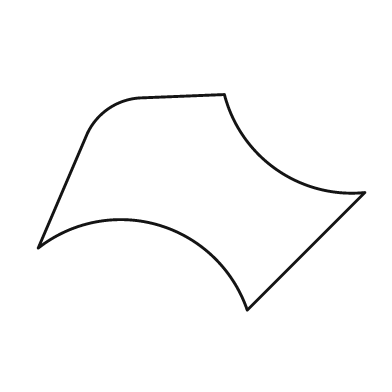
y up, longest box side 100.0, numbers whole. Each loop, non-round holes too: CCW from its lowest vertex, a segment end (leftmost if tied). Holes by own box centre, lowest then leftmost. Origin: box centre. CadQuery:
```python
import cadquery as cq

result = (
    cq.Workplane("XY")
    .moveTo(14.0, -33.0)
    .lineTo(50.0, 3.0)
    .threePointArc((23.0, 10.0), (7.0, 33.0))
    .lineTo(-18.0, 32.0)
    .threePointArc((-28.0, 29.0), (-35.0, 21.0))
    .lineTo(-50.0, -14.0)
    .threePointArc((-13.0, -7.0), (14.0, -33.0))
    .close()
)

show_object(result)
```